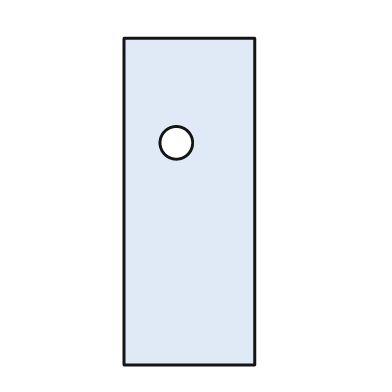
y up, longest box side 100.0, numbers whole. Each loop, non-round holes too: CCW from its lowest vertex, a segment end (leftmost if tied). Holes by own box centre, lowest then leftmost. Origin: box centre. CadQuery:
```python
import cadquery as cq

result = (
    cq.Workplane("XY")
    .moveTo(-20.0, -50.0)
    .lineTo(20.0, -50.0)
    .lineTo(20.0, 50.0)
    .lineTo(-20.0, 50.0)
    .close()
    .moveTo(-4.0, 18.0)
    .circle(5.0)
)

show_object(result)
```